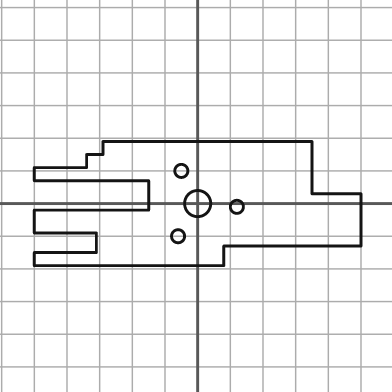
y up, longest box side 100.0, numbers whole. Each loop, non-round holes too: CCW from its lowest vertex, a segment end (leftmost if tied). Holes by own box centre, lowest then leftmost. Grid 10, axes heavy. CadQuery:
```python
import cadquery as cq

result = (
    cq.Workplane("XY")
    .moveTo(-50.0, -19.0)
    .lineTo(8.0, -19.0)
    .lineTo(8.0, -13.0)
    .lineTo(50.0, -13.0)
    .lineTo(50.0, 3.0)
    .lineTo(35.0, 3.0)
    .lineTo(35.0, 19.0)
    .lineTo(-29.0, 19.0)
    .lineTo(-29.0, 15.0)
    .lineTo(-34.0, 15.0)
    .lineTo(-34.0, 11.0)
    .lineTo(-50.0, 11.0)
    .lineTo(-50.0, 7.0)
    .lineTo(-15.0, 7.0)
    .lineTo(-15.0, -2.0)
    .lineTo(-50.0, -2.0)
    .lineTo(-50.0, -9.0)
    .lineTo(-31.0, -9.0)
    .lineTo(-31.0, -15.0)
    .lineTo(-50.0, -15.0)
    .close()
    .moveTo(-6.0, -10.0)
    .circle(2.0)
    .moveTo(12.0, -1.0)
    .circle(2.0)
    .moveTo(0.0, 0.0)
    .circle(4.0)
    .moveTo(-5.0, 10.0)
    .circle(2.0)
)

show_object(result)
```